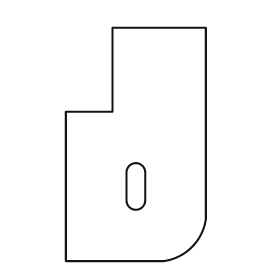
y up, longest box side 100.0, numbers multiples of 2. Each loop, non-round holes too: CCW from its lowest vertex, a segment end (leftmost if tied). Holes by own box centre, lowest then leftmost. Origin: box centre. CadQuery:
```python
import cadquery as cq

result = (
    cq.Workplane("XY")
    .moveTo(-30.0, -50.0)
    .lineTo(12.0, -50.0)
    .threePointArc((24.0, -44.0), (30.0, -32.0))
    .lineTo(30.0, 50.0)
    .lineTo(-10.0, 50.0)
    .lineTo(-10.0, 14.0)
    .lineTo(-30.0, 14.0)
    .close()
    .moveTo(-4.0, -24.0)
    .threePointArc((0.0, -28.0), (4.0, -24.0))
    .lineTo(4.0, -12.0)
    .threePointArc((0.0, -8.0), (-4.0, -12.0))
    .close()
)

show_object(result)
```